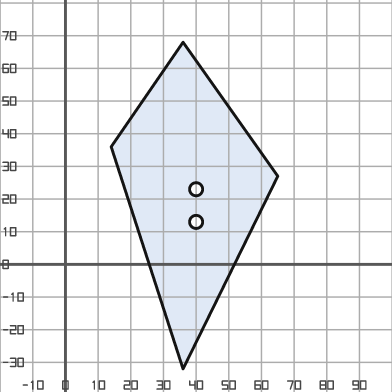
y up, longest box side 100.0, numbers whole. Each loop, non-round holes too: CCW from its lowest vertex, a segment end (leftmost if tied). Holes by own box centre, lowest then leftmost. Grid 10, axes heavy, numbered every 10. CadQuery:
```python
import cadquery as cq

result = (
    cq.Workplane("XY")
    .moveTo(36.0, -32.0)
    .lineTo(65.0, 27.0)
    .lineTo(36.0, 68.0)
    .lineTo(14.0, 36.0)
    .close()
    .moveTo(40.0, 13.0)
    .circle(2.0)
    .moveTo(40.0, 23.0)
    .circle(2.0)
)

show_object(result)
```